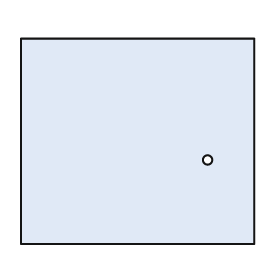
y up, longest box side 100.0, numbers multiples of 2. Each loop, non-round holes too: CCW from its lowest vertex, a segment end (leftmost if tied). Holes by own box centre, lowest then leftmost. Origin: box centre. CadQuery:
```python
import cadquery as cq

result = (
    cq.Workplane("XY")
    .moveTo(-50.0, -44.0)
    .lineTo(50.0, -44.0)
    .lineTo(50.0, 44.0)
    .lineTo(-50.0, 44.0)
    .close()
    .moveTo(30.0, -8.0)
    .circle(2.0)
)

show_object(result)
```